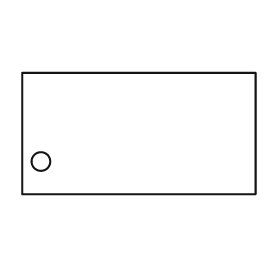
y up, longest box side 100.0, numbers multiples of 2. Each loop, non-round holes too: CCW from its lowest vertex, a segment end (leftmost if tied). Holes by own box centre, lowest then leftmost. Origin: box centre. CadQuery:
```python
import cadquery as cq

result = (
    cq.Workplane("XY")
    .moveTo(-50.0, -26.0)
    .lineTo(50.0, -26.0)
    .lineTo(50.0, 26.0)
    .lineTo(-50.0, 26.0)
    .close()
    .moveTo(-42.0, -12.0)
    .circle(4.0)
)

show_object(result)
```